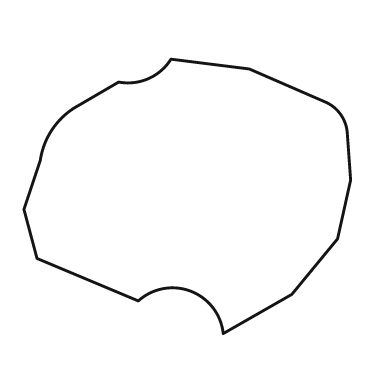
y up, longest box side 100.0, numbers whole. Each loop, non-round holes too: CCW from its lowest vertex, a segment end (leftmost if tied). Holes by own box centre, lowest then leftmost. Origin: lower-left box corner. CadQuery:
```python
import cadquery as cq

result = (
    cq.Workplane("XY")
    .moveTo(61.0, 0.0)
    .lineTo(82.0, 12.0)
    .lineTo(96.0, 29.0)
    .lineTo(100.0, 47.0)
    .lineTo(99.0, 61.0)
    .threePointArc((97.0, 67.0), (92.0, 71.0))
    .lineTo(69.0, 81.0)
    .lineTo(45.0, 84.0)
    .threePointArc((38.0, 78.0), (29.0, 77.0))
    .lineTo(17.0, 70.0)
    .threePointArc((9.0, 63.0), (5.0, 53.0))
    .lineTo(0.0, 38.0)
    .lineTo(4.0, 23.0)
    .lineTo(35.0, 10.0)
    .threePointArc((51.0, 13.0), (61.0, 0.0))
    .close()
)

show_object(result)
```